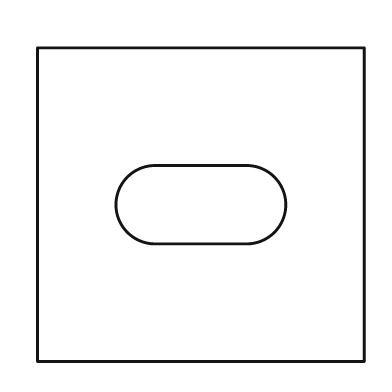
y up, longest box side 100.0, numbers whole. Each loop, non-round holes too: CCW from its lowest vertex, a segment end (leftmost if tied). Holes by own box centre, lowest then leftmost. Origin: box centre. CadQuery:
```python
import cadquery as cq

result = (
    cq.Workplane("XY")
    .moveTo(-50.0, -48.0)
    .lineTo(50.0, -48.0)
    .lineTo(50.0, 48.0)
    .lineTo(-50.0, 48.0)
    .close()
    .moveTo(-14.0, -12.0)
    .lineTo(14.0, -12.0)
    .threePointArc((26.0, 0.0), (14.0, 12.0))
    .lineTo(-14.0, 12.0)
    .threePointArc((-26.0, 0.0), (-14.0, -12.0))
    .close()
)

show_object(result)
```